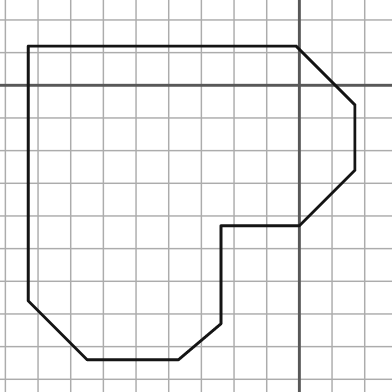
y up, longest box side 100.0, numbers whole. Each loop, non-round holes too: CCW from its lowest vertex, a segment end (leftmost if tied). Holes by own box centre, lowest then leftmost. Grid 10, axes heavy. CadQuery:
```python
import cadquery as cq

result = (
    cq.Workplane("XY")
    .moveTo(-65.0, -84.0)
    .lineTo(-37.0, -84.0)
    .lineTo(-24.0, -73.0)
    .lineTo(-24.0, -43.0)
    .lineTo(0.0, -43.0)
    .lineTo(17.0, -26.0)
    .lineTo(17.0, -6.0)
    .lineTo(-1.0, 12.0)
    .lineTo(-83.0, 12.0)
    .lineTo(-83.0, -66.0)
    .close()
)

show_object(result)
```